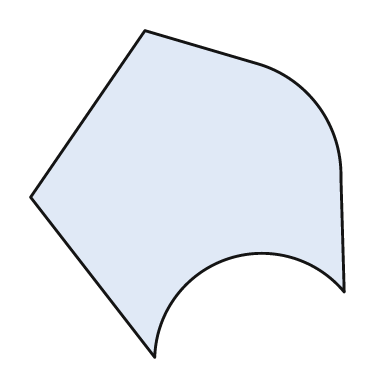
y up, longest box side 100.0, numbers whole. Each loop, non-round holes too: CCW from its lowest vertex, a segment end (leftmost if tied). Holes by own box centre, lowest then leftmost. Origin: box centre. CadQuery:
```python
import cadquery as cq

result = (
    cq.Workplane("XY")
    .moveTo(-10.0, -50.0)
    .threePointArc((12.0, -20.0), (48.0, -30.0))
    .lineTo(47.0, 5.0)
    .threePointArc((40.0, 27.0), (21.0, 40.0))
    .lineTo(-13.0, 50.0)
    .lineTo(-48.0, -1.0)
    .close()
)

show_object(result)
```